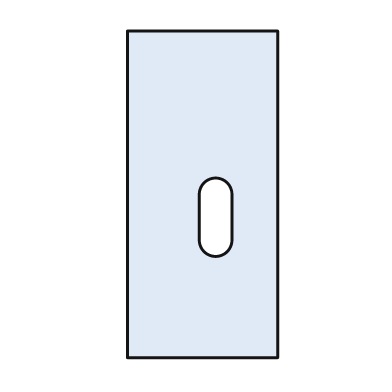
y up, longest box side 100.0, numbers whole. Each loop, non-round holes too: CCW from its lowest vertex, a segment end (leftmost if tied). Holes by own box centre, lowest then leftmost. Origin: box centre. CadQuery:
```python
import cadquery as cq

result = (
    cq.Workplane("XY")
    .moveTo(-23.0, -50.0)
    .lineTo(23.0, -50.0)
    .lineTo(23.0, 50.0)
    .lineTo(-23.0, 50.0)
    .close()
    .moveTo(-1.0, -14.0)
    .threePointArc((4.0, -19.0), (9.0, -14.0))
    .lineTo(9.0, 0.0)
    .threePointArc((4.0, 5.0), (-1.0, 0.0))
    .close()
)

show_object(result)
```